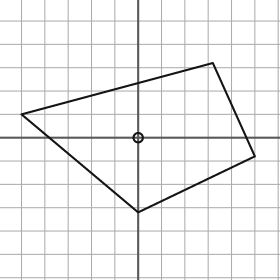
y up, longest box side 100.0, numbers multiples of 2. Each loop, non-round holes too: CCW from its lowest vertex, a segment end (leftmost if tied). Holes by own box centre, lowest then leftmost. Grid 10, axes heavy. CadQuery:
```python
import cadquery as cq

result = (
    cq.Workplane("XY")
    .moveTo(0.0, -32.0)
    .lineTo(50.0, -8.0)
    .lineTo(32.0, 32.0)
    .lineTo(-50.0, 10.0)
    .close()
    .moveTo(0.0, 0.0)
    .circle(2.0)
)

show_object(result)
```